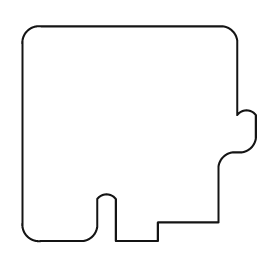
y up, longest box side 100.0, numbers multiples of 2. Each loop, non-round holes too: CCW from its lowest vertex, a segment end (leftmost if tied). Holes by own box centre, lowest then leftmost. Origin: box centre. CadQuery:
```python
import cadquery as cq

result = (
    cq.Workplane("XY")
    .moveTo(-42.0, -46.0)
    .lineTo(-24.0, -46.0)
    .threePointArc((-20.0, -44.0), (-18.0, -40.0))
    .lineTo(-18.0, -28.0)
    .threePointArc((-14.0, -26.0), (-10.0, -28.0))
    .lineTo(-10.0, -46.0)
    .lineTo(8.0, -46.0)
    .lineTo(8.0, -38.0)
    .lineTo(34.0, -38.0)
    .lineTo(34.0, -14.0)
    .threePointArc((36.0, -10.0), (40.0, -8.0))
    .lineTo(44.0, -8.0)
    .threePointArc((48.0, -6.0), (50.0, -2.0))
    .lineTo(50.0, 8.0)
    .threePointArc((46.0, 10.0), (42.0, 8.0))
    .lineTo(42.0, 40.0)
    .threePointArc((40.0, 44.0), (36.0, 46.0))
    .lineTo(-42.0, 46.0)
    .threePointArc((-48.0, 44.0), (-50.0, 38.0))
    .lineTo(-50.0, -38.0)
    .threePointArc((-48.0, -44.0), (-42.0, -46.0))
    .close()
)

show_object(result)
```